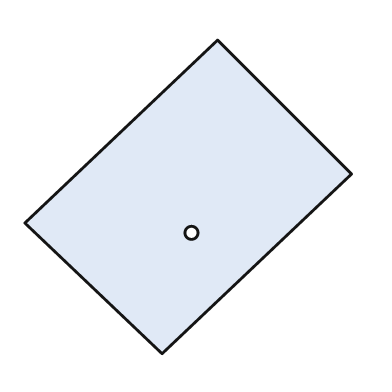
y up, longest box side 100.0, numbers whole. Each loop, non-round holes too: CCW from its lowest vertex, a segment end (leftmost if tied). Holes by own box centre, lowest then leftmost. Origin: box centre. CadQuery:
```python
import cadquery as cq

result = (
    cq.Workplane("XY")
    .moveTo(-8.0, -48.0)
    .lineTo(50.0, 7.0)
    .lineTo(9.0, 48.0)
    .lineTo(-50.0, -8.0)
    .close()
    .moveTo(1.0, -11.0)
    .circle(2.0)
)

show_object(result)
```